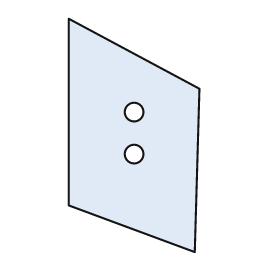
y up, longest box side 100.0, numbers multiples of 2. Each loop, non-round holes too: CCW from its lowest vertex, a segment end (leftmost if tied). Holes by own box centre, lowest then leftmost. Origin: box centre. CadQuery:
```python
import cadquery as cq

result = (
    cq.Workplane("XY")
    .moveTo(26.0, -50.0)
    .lineTo(28.0, 20.0)
    .lineTo(-28.0, 50.0)
    .lineTo(-28.0, -30.0)
    .close()
    .moveTo(0.0, -8.0)
    .circle(4.0)
    .moveTo(0.0, 10.0)
    .circle(4.0)
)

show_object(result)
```